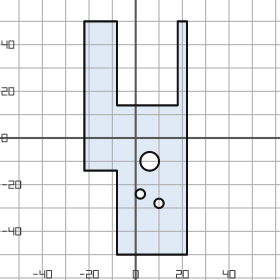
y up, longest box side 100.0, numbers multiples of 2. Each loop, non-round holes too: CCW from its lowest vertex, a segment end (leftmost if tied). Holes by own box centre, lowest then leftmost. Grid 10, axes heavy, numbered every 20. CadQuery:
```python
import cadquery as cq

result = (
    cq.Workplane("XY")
    .moveTo(-8.0, -50.0)
    .lineTo(22.0, -50.0)
    .lineTo(22.0, 50.0)
    .lineTo(18.0, 50.0)
    .lineTo(18.0, 14.0)
    .lineTo(-8.0, 14.0)
    .lineTo(-8.0, 50.0)
    .lineTo(-22.0, 50.0)
    .lineTo(-22.0, -14.0)
    .lineTo(-8.0, -14.0)
    .close()
    .moveTo(10.0, -28.0)
    .circle(2.0)
    .moveTo(2.0, -24.0)
    .circle(2.0)
    .moveTo(6.0, -10.0)
    .circle(4.0)
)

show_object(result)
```